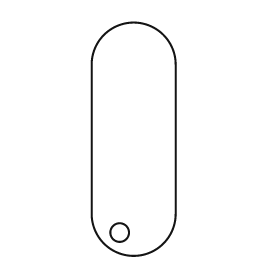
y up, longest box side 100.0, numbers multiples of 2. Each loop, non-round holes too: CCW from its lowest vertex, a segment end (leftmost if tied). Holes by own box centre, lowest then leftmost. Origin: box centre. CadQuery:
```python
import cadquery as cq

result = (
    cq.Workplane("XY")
    .moveTo(-18.0, -32.0)
    .threePointArc((0.0, -50.0), (18.0, -32.0))
    .lineTo(18.0, 32.0)
    .threePointArc((0.0, 50.0), (-18.0, 32.0))
    .close()
    .moveTo(-6.0, -40.0)
    .circle(4.0)
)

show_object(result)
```